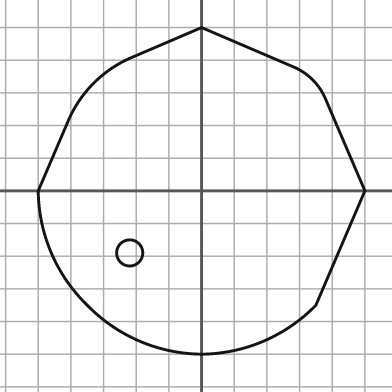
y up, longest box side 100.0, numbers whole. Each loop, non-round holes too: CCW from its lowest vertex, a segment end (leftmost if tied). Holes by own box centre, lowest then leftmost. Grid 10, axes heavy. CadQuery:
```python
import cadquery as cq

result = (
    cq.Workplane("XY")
    .moveTo(0.0, -50.0)
    .threePointArc((19.0, -46.0), (35.0, -35.0))
    .lineTo(50.0, 0.0)
    .lineTo(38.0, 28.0)
    .threePointArc((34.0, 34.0), (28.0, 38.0))
    .lineTo(0.0, 50.0)
    .lineTo(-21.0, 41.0)
    .threePointArc((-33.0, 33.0), (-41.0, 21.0))
    .lineTo(-50.0, 0.0)
    .threePointArc((-46.0, -19.0), (-35.0, -35.0))
    .threePointArc((-19.0, -46.0), (0.0, -50.0))
    .close()
    .moveTo(-22.0, -19.0)
    .circle(4.0)
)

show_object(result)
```